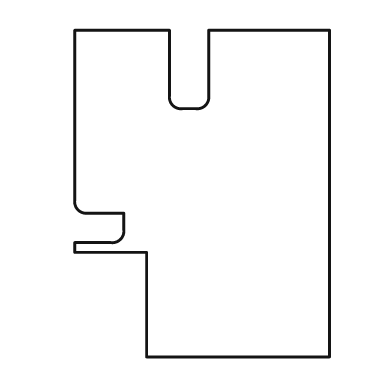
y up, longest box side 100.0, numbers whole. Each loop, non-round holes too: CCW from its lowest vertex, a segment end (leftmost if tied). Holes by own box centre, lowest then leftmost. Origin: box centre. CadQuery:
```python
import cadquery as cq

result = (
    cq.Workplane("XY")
    .moveTo(-17.0, -50.0)
    .lineTo(39.0, -50.0)
    .lineTo(39.0, 50.0)
    .lineTo(2.0, 50.0)
    .lineTo(2.0, 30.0)
    .threePointArc((1.0, 27.0), (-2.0, 26.0))
    .lineTo(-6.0, 26.0)
    .threePointArc((-9.0, 27.0), (-10.0, 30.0))
    .lineTo(-10.0, 50.0)
    .lineTo(-39.0, 50.0)
    .lineTo(-39.0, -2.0)
    .threePointArc((-38.0, -5.0), (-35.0, -6.0))
    .lineTo(-24.0, -6.0)
    .lineTo(-24.0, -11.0)
    .threePointArc((-25.0, -14.0), (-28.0, -15.0))
    .lineTo(-39.0, -15.0)
    .lineTo(-39.0, -18.0)
    .lineTo(-17.0, -18.0)
    .close()
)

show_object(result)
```